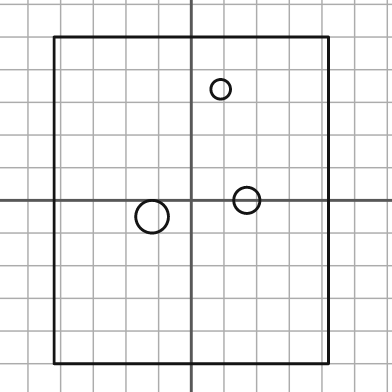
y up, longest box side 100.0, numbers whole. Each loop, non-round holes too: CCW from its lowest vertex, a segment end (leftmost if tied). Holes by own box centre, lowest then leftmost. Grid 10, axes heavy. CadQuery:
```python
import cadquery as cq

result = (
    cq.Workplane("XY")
    .moveTo(-42.0, -50.0)
    .lineTo(42.0, -50.0)
    .lineTo(42.0, 50.0)
    .lineTo(-42.0, 50.0)
    .close()
    .moveTo(-12.0, -5.0)
    .circle(5.0)
    .moveTo(17.0, 0.0)
    .circle(4.0)
    .moveTo(9.0, 34.0)
    .circle(3.0)
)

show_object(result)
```